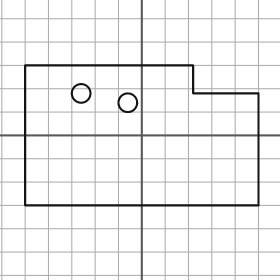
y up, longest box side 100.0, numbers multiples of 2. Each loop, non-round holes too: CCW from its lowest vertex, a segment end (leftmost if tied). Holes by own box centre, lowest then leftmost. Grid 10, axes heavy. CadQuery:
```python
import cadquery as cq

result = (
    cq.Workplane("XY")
    .moveTo(-50.0, -30.0)
    .lineTo(50.0, -30.0)
    .lineTo(50.0, 18.0)
    .lineTo(22.0, 18.0)
    .lineTo(22.0, 30.0)
    .lineTo(-50.0, 30.0)
    .close()
    .moveTo(-6.0, 14.0)
    .circle(4.0)
    .moveTo(-26.0, 18.0)
    .circle(4.0)
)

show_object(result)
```